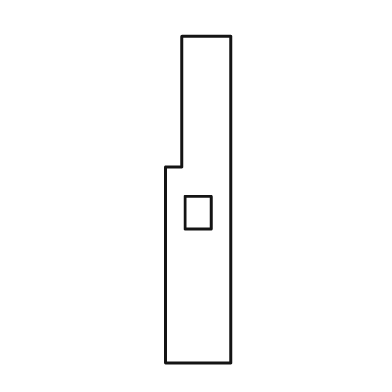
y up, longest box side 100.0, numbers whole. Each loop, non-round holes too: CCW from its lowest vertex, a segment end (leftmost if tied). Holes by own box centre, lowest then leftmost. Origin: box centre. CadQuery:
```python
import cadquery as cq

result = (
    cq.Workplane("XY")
    .moveTo(-10.0, -50.0)
    .lineTo(10.0, -50.0)
    .lineTo(10.0, 50.0)
    .lineTo(-5.0, 50.0)
    .lineTo(-5.0, 10.0)
    .lineTo(-10.0, 10.0)
    .close()
    .moveTo(-4.0, -9.0)
    .lineTo(4.0, -9.0)
    .lineTo(4.0, 1.0)
    .lineTo(-4.0, 1.0)
    .close()
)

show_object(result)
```